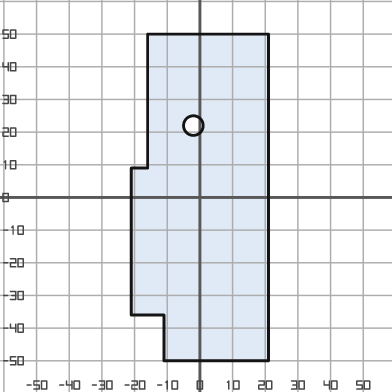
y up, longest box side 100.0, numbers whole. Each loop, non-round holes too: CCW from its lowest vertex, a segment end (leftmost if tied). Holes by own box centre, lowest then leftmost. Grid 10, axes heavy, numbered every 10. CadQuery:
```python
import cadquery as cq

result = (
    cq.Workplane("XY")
    .moveTo(-11.0, -50.0)
    .lineTo(21.0, -50.0)
    .lineTo(21.0, 50.0)
    .lineTo(-16.0, 50.0)
    .lineTo(-16.0, 9.0)
    .lineTo(-21.0, 9.0)
    .lineTo(-21.0, -36.0)
    .lineTo(-11.0, -36.0)
    .close()
    .moveTo(-2.0, 22.0)
    .circle(3.0)
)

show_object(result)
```